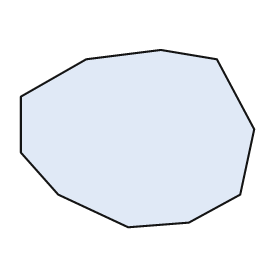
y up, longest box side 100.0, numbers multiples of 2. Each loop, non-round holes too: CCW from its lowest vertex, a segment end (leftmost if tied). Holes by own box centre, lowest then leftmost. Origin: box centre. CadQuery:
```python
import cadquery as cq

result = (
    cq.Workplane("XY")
    .moveTo(-4.0, -38.0)
    .lineTo(22.0, -36.0)
    .lineTo(44.0, -24.0)
    .lineTo(50.0, 4.0)
    .lineTo(34.0, 34.0)
    .lineTo(10.0, 38.0)
    .lineTo(-22.0, 34.0)
    .lineTo(-50.0, 18.0)
    .lineTo(-50.0, -6.0)
    .lineTo(-34.0, -24.0)
    .close()
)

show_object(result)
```